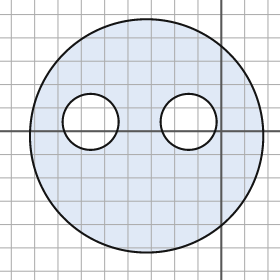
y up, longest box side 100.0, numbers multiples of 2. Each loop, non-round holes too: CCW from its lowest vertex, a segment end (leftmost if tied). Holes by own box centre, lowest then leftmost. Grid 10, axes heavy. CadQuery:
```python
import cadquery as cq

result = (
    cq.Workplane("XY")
    .moveTo(-32.0, -2.0)
    .circle(50.0)
    .moveTo(-56.0, 4.0)
    .circle(12.0)
    .moveTo(-14.0, 4.0)
    .circle(12.0)
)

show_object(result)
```